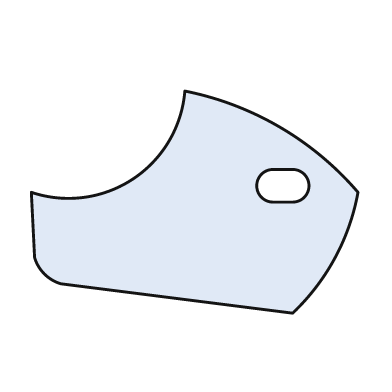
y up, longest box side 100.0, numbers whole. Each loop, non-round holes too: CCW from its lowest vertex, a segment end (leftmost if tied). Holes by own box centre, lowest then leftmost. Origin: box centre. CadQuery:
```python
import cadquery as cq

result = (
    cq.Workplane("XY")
    .moveTo(30.0, -34.0)
    .threePointArc((43.0, -17.0), (50.0, 3.0))
    .threePointArc((26.0, 23.0), (-3.0, 34.0))
    .threePointArc((-19.0, 7.0), (-50.0, 3.0))
    .lineTo(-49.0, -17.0)
    .threePointArc((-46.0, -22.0), (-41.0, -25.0))
    .close()
    .moveTo(24.0, 0.0)
    .lineTo(30.0, 0.0)
    .threePointArc((35.0, 5.0), (30.0, 10.0))
    .lineTo(24.0, 10.0)
    .threePointArc((19.0, 5.0), (24.0, 0.0))
    .close()
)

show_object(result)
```